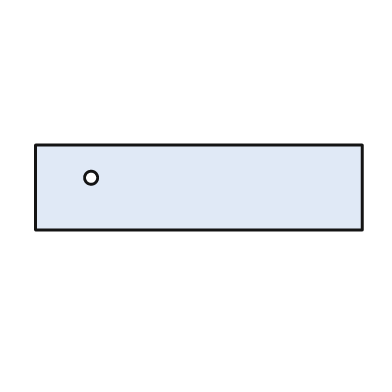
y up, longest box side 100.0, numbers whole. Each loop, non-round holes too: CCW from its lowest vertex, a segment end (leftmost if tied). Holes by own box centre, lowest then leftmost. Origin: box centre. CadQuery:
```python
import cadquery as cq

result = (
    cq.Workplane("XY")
    .moveTo(-50.0, -13.0)
    .lineTo(50.0, -13.0)
    .lineTo(50.0, 13.0)
    .lineTo(-50.0, 13.0)
    .close()
    .moveTo(-33.0, 3.0)
    .circle(2.0)
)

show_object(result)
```